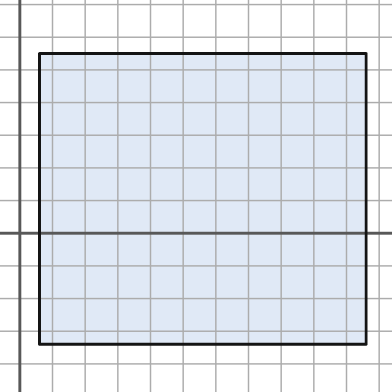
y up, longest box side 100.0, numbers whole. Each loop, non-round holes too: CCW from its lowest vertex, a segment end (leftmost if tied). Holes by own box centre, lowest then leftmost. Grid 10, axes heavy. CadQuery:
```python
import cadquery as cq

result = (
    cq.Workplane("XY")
    .moveTo(6.0, -34.0)
    .lineTo(106.0, -34.0)
    .lineTo(106.0, 55.0)
    .lineTo(6.0, 55.0)
    .close()
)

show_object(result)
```